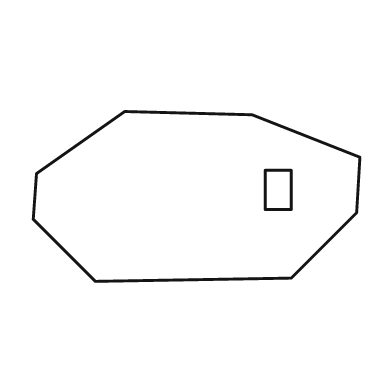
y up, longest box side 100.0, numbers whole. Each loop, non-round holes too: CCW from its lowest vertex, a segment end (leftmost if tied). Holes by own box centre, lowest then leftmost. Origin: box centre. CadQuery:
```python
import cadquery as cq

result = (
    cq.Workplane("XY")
    .moveTo(-31.0, -26.0)
    .lineTo(29.0, -25.0)
    .lineTo(49.0, -5.0)
    .lineTo(50.0, 12.0)
    .lineTo(17.0, 25.0)
    .lineTo(-22.0, 26.0)
    .lineTo(-49.0, 7.0)
    .lineTo(-50.0, -7.0)
    .close()
    .moveTo(21.0, -4.0)
    .lineTo(29.0, -4.0)
    .lineTo(29.0, 8.0)
    .lineTo(21.0, 8.0)
    .close()
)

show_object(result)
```